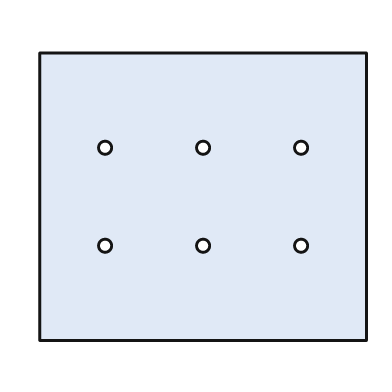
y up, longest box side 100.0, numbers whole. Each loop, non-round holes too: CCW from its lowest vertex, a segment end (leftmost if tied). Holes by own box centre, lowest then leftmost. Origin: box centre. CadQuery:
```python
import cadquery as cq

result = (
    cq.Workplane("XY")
    .moveTo(-50.0, -44.0)
    .lineTo(50.0, -44.0)
    .lineTo(50.0, 44.0)
    .lineTo(-50.0, 44.0)
    .close()
    .moveTo(-30.0, -15.0)
    .circle(2.0)
    .moveTo(0.0, -15.0)
    .circle(2.0)
    .moveTo(30.0, -15.0)
    .circle(2.0)
    .moveTo(-30.0, 15.0)
    .circle(2.0)
    .moveTo(0.0, 15.0)
    .circle(2.0)
    .moveTo(30.0, 15.0)
    .circle(2.0)
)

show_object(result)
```